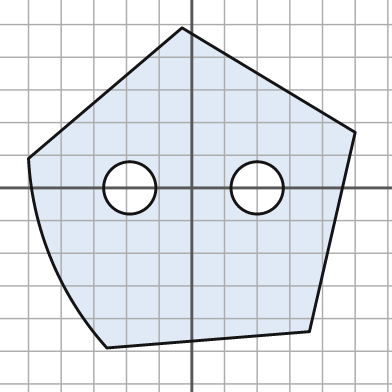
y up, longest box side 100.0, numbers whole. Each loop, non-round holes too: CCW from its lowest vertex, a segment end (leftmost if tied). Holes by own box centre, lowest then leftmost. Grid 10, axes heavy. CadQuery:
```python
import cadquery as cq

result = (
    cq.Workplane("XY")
    .moveTo(-26.0, -49.0)
    .lineTo(36.0, -44.0)
    .lineTo(50.0, 17.0)
    .lineTo(-3.0, 49.0)
    .lineTo(-50.0, 9.0)
    .threePointArc((-43.0, -22.0), (-26.0, -49.0))
    .close()
    .moveTo(-19.0, 0.0)
    .circle(8.0)
    .moveTo(20.0, 0.0)
    .circle(8.0)
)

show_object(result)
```